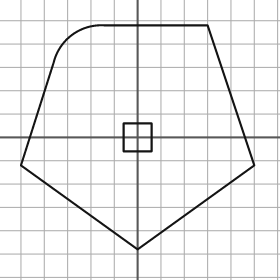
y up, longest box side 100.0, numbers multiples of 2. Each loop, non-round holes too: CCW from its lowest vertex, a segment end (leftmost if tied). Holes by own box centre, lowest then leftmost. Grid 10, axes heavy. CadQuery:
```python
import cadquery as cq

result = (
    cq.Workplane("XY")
    .moveTo(0.0, -48.0)
    .lineTo(50.0, -12.0)
    .lineTo(30.0, 48.0)
    .lineTo(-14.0, 48.0)
    .threePointArc((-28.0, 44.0), (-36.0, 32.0))
    .lineTo(-50.0, -12.0)
    .close()
    .moveTo(-6.0, -6.0)
    .lineTo(6.0, -6.0)
    .lineTo(6.0, 6.0)
    .lineTo(-6.0, 6.0)
    .close()
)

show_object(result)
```